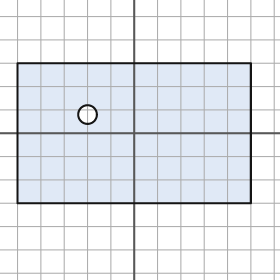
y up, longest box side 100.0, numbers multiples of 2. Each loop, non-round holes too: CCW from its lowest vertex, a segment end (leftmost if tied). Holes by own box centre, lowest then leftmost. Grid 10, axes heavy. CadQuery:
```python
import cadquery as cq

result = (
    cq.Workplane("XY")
    .moveTo(-50.0, -30.0)
    .lineTo(50.0, -30.0)
    .lineTo(50.0, 30.0)
    .lineTo(-50.0, 30.0)
    .close()
    .moveTo(-20.0, 8.0)
    .circle(4.0)
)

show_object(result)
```